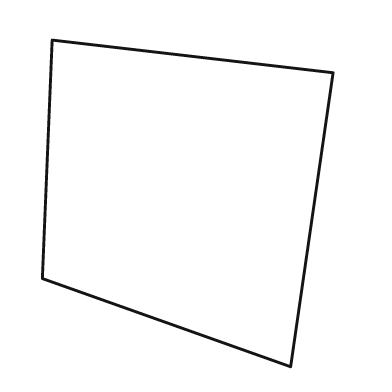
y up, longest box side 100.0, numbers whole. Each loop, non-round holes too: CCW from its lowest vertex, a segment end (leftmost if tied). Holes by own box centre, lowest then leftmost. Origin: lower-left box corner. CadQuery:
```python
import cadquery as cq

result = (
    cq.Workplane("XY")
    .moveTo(76.0, 0.0)
    .lineTo(89.0, 90.0)
    .lineTo(3.0, 100.0)
    .lineTo(0.0, 27.0)
    .close()
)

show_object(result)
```